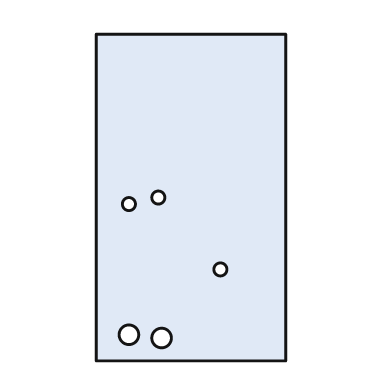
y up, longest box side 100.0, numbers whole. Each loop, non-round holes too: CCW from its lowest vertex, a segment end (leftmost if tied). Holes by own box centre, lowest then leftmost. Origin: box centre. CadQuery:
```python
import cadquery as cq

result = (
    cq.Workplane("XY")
    .moveTo(-29.0, -50.0)
    .lineTo(29.0, -50.0)
    .lineTo(29.0, 50.0)
    .lineTo(-29.0, 50.0)
    .close()
    .moveTo(-9.0, -43.0)
    .circle(3.0)
    .moveTo(-19.0, -42.0)
    .circle(3.0)
    .moveTo(9.0, -22.0)
    .circle(2.0)
    .moveTo(-19.0, -2.0)
    .circle(2.0)
    .moveTo(-10.0, 0.0)
    .circle(2.0)
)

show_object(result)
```